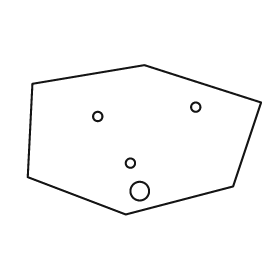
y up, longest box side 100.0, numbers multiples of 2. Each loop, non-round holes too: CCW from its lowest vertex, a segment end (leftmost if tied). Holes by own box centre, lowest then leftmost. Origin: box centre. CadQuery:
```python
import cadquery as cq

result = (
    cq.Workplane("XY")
    .moveTo(-8.0, -32.0)
    .lineTo(38.0, -20.0)
    .lineTo(50.0, 16.0)
    .lineTo(0.0, 32.0)
    .lineTo(-48.0, 24.0)
    .lineTo(-50.0, -16.0)
    .close()
    .moveTo(-2.0, -22.0)
    .circle(4.0)
    .moveTo(-6.0, -10.0)
    .circle(2.0)
    .moveTo(-20.0, 10.0)
    .circle(2.0)
    .moveTo(22.0, 14.0)
    .circle(2.0)
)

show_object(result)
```